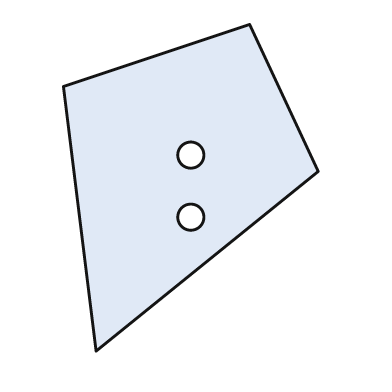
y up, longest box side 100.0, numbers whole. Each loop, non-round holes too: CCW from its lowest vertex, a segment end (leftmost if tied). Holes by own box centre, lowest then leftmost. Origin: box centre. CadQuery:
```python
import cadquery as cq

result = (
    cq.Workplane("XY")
    .moveTo(-29.0, -50.0)
    .lineTo(39.0, 5.0)
    .lineTo(18.0, 50.0)
    .lineTo(-39.0, 31.0)
    .close()
    .moveTo(0.0, -9.0)
    .circle(4.0)
    .moveTo(0.0, 10.0)
    .circle(4.0)
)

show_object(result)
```